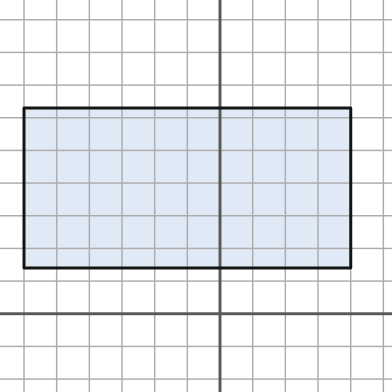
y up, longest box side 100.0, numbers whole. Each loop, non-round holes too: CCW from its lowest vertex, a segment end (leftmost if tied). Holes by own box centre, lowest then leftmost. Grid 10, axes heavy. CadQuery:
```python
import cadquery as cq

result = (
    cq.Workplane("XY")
    .moveTo(-60.0, 14.0)
    .lineTo(40.0, 14.0)
    .lineTo(40.0, 63.0)
    .lineTo(-60.0, 63.0)
    .close()
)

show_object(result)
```